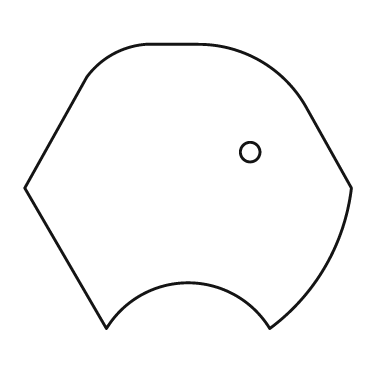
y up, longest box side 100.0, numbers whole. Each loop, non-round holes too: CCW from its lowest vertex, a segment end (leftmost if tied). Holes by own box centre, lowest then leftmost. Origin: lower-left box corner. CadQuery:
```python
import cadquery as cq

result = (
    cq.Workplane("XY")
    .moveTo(25.0, 0.0)
    .threePointArc((50.0, 14.0), (75.0, 0.0))
    .threePointArc((92.0, 19.0), (100.0, 43.0))
    .lineTo(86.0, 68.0)
    .threePointArc((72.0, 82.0), (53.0, 87.0))
    .lineTo(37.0, 87.0)
    .threePointArc((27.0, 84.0), (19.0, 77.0))
    .lineTo(0.0, 43.0)
    .close()
    .moveTo(69.0, 54.0)
    .circle(3.0)
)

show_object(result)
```